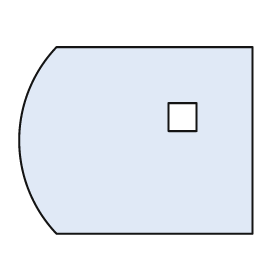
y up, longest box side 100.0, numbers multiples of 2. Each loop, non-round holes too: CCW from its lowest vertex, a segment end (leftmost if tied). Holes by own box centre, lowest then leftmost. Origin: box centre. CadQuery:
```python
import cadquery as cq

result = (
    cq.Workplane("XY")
    .moveTo(-34.0, -40.0)
    .lineTo(50.0, -40.0)
    .lineTo(50.0, 40.0)
    .lineTo(-34.0, 40.0)
    .threePointArc((-50.0, 0.0), (-34.0, -40.0))
    .close()
    .moveTo(14.0, 4.0)
    .lineTo(26.0, 4.0)
    .lineTo(26.0, 16.0)
    .lineTo(14.0, 16.0)
    .close()
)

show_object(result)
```